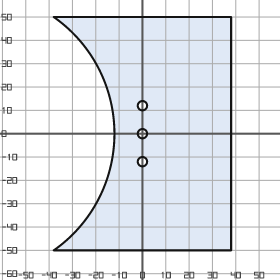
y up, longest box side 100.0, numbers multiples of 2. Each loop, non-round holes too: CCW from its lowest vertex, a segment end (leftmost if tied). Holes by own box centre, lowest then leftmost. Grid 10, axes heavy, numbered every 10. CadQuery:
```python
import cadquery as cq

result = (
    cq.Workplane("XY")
    .moveTo(-38.0, -50.0)
    .lineTo(38.0, -50.0)
    .lineTo(38.0, 50.0)
    .lineTo(-38.0, 50.0)
    .threePointArc((-12.0, 0.0), (-38.0, -50.0))
    .close()
    .moveTo(0.0, -12.0)
    .circle(2.0)
    .moveTo(0.0, 0.0)
    .circle(2.0)
    .moveTo(0.0, 12.0)
    .circle(2.0)
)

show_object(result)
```